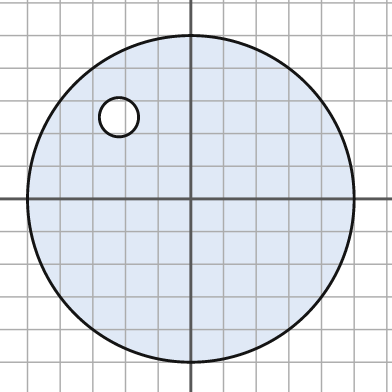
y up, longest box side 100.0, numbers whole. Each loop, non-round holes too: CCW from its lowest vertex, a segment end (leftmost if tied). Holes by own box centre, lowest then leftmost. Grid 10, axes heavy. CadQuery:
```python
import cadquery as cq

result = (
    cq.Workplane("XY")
    .moveTo(0.0, 0.0)
    .circle(50.0)
    .moveTo(-22.0, 25.0)
    .circle(6.0)
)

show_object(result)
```